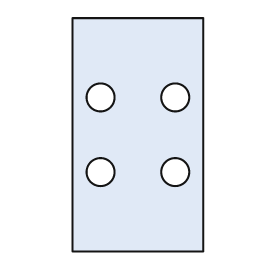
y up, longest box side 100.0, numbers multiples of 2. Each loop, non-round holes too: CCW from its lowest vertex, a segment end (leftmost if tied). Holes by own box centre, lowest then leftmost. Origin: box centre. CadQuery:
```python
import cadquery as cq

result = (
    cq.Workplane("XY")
    .moveTo(-28.0, -50.0)
    .lineTo(28.0, -50.0)
    .lineTo(28.0, 50.0)
    .lineTo(-28.0, 50.0)
    .close()
    .moveTo(-16.0, -16.0)
    .circle(6.0)
    .moveTo(16.0, -16.0)
    .circle(6.0)
    .moveTo(-16.0, 16.0)
    .circle(6.0)
    .moveTo(16.0, 16.0)
    .circle(6.0)
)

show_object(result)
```